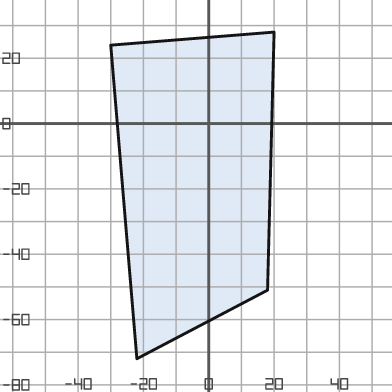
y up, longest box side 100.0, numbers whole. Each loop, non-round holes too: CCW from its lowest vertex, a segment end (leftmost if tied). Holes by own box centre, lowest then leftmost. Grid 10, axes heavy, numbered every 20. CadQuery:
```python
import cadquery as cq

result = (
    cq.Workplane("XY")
    .moveTo(-22.0, -72.0)
    .lineTo(18.0, -51.0)
    .lineTo(20.0, 28.0)
    .lineTo(-30.0, 24.0)
    .close()
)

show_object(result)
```